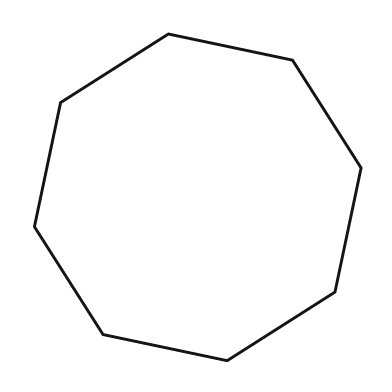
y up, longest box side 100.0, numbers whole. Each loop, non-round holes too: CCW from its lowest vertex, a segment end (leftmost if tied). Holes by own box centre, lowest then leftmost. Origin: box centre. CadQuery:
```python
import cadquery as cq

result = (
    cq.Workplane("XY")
    .moveTo(9.0, -50.0)
    .lineTo(42.0, -29.0)
    .lineTo(50.0, 9.0)
    .lineTo(29.0, 42.0)
    .lineTo(-9.0, 50.0)
    .lineTo(-42.0, 29.0)
    .lineTo(-50.0, -9.0)
    .lineTo(-29.0, -42.0)
    .close()
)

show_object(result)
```